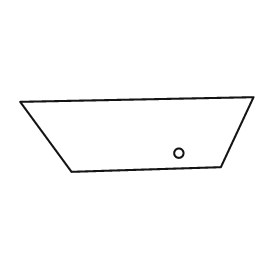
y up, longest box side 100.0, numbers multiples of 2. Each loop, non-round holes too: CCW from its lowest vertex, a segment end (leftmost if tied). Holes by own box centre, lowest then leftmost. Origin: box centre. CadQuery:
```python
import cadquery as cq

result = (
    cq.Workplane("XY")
    .moveTo(-28.0, -16.0)
    .lineTo(36.0, -14.0)
    .lineTo(50.0, 16.0)
    .lineTo(-50.0, 14.0)
    .close()
    .moveTo(18.0, -8.0)
    .circle(2.0)
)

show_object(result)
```